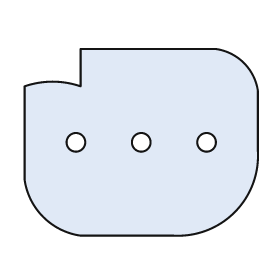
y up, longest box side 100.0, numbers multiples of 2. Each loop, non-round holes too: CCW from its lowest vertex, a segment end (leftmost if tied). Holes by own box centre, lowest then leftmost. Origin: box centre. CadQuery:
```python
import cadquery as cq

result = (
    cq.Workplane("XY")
    .moveTo(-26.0, -40.0)
    .lineTo(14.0, -40.0)
    .threePointArc((40.0, -30.0), (50.0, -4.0))
    .lineTo(50.0, 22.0)
    .threePointArc((44.0, 34.0), (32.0, 40.0))
    .lineTo(-26.0, 40.0)
    .lineTo(-26.0, 24.0)
    .threePointArc((-38.0, 26.0), (-50.0, 24.0))
    .lineTo(-50.0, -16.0)
    .threePointArc((-42.0, -32.0), (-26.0, -40.0))
    .close()
    .moveTo(-28.0, 0.0)
    .circle(4.0)
    .moveTo(0.0, 0.0)
    .circle(4.0)
    .moveTo(28.0, 0.0)
    .circle(4.0)
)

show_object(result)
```